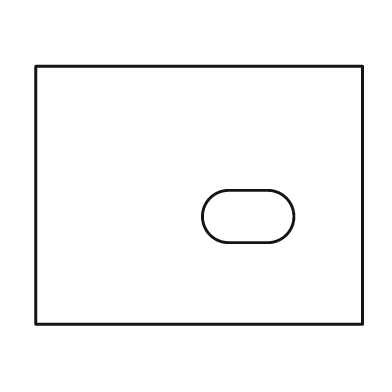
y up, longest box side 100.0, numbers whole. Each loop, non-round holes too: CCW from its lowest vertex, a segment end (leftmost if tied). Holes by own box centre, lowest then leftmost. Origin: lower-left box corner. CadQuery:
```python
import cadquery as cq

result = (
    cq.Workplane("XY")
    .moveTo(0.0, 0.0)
    .lineTo(100.0, 0.0)
    .lineTo(100.0, 79.0)
    .lineTo(0.0, 79.0)
    .close()
    .moveTo(59.0, 25.0)
    .lineTo(71.0, 25.0)
    .threePointArc((79.0, 33.0), (71.0, 41.0))
    .lineTo(59.0, 41.0)
    .threePointArc((51.0, 33.0), (59.0, 25.0))
    .close()
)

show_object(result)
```